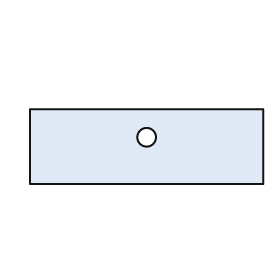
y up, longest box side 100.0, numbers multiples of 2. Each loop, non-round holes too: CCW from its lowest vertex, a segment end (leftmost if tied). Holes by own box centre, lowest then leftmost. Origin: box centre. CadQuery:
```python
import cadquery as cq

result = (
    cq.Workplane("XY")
    .moveTo(-50.0, -16.0)
    .lineTo(50.0, -16.0)
    .lineTo(50.0, 16.0)
    .lineTo(-50.0, 16.0)
    .close()
    .moveTo(0.0, 4.0)
    .circle(4.0)
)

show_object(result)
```